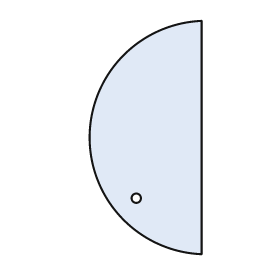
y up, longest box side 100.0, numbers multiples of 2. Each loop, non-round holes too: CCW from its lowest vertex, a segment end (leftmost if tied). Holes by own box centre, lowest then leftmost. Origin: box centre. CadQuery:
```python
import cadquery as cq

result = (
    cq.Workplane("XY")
    .moveTo(24.0, -50.0)
    .lineTo(24.0, 50.0)
    .threePointArc((-24.0, 0.0), (24.0, -50.0))
    .close()
    .moveTo(-4.0, -26.0)
    .circle(2.0)
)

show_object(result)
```